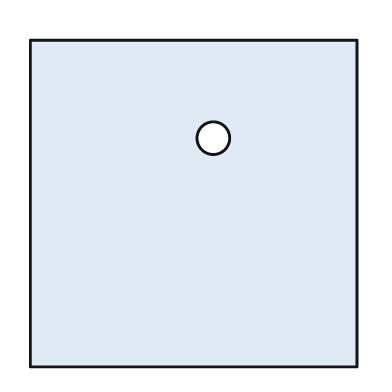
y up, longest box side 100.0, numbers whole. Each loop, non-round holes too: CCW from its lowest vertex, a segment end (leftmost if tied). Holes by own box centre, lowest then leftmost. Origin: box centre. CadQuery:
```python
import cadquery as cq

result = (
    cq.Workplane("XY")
    .moveTo(-50.0, -50.0)
    .lineTo(50.0, -50.0)
    .lineTo(50.0, 50.0)
    .lineTo(-50.0, 50.0)
    .close()
    .moveTo(6.0, 20.0)
    .circle(5.0)
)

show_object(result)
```